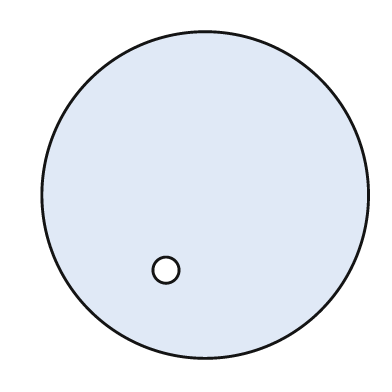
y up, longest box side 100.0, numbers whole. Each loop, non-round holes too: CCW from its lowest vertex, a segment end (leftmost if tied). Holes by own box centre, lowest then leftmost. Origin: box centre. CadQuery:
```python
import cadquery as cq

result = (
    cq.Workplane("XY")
    .moveTo(0.0, 0.0)
    .circle(50.0)
    .moveTo(-12.0, -23.0)
    .circle(4.0)
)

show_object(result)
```